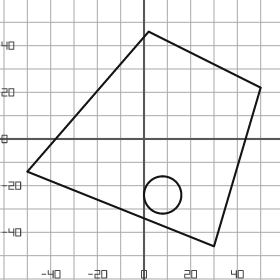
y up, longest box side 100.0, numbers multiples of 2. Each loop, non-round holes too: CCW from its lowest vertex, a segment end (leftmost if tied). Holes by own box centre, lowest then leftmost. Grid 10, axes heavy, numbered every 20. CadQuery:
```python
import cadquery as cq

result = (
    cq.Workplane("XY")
    .moveTo(30.0, -46.0)
    .lineTo(50.0, 22.0)
    .lineTo(2.0, 46.0)
    .lineTo(-50.0, -14.0)
    .close()
    .moveTo(8.0, -24.0)
    .circle(8.0)
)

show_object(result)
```